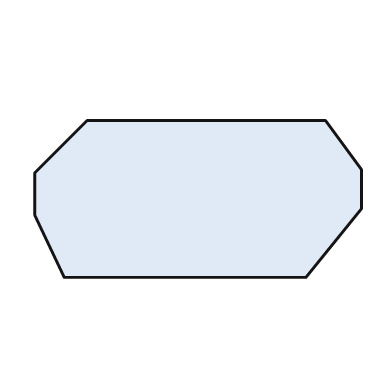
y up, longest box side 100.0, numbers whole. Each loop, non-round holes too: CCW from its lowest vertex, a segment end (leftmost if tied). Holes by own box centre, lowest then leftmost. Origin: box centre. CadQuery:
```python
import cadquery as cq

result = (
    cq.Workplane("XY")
    .moveTo(-41.0, -24.0)
    .lineTo(33.0, -24.0)
    .lineTo(50.0, -3.0)
    .lineTo(50.0, 9.0)
    .lineTo(39.0, 24.0)
    .lineTo(-34.0, 24.0)
    .lineTo(-50.0, 8.0)
    .lineTo(-50.0, -5.0)
    .close()
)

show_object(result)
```